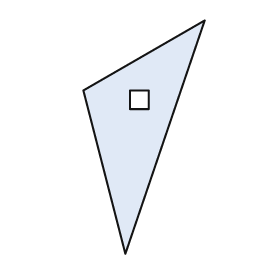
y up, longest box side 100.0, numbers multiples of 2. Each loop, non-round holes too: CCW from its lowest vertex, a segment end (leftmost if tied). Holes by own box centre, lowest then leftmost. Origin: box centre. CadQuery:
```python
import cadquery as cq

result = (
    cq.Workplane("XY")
    .moveTo(-8.0, -50.0)
    .lineTo(26.0, 50.0)
    .lineTo(-26.0, 20.0)
    .close()
    .moveTo(-6.0, 12.0)
    .lineTo(2.0, 12.0)
    .lineTo(2.0, 20.0)
    .lineTo(-6.0, 20.0)
    .close()
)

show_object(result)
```